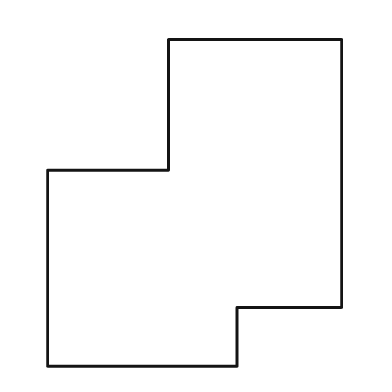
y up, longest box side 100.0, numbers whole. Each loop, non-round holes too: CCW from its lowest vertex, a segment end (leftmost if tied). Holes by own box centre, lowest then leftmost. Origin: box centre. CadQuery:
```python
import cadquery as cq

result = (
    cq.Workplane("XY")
    .moveTo(-45.0, -50.0)
    .lineTo(13.0, -50.0)
    .lineTo(13.0, -32.0)
    .lineTo(45.0, -32.0)
    .lineTo(45.0, 50.0)
    .lineTo(-8.0, 50.0)
    .lineTo(-8.0, 10.0)
    .lineTo(-45.0, 10.0)
    .close()
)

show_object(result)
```